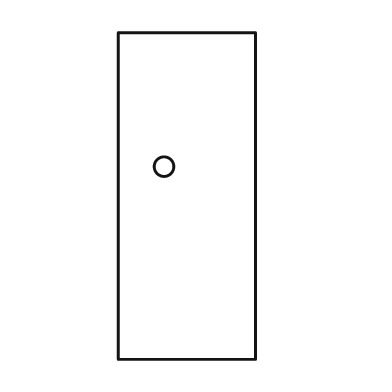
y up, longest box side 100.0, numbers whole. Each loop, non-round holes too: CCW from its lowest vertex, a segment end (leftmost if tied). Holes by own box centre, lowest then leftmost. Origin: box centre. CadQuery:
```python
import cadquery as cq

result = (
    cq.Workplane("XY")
    .moveTo(-21.0, -50.0)
    .lineTo(21.0, -50.0)
    .lineTo(21.0, 50.0)
    .lineTo(-21.0, 50.0)
    .close()
    .moveTo(-7.0, 9.0)
    .circle(3.0)
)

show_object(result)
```